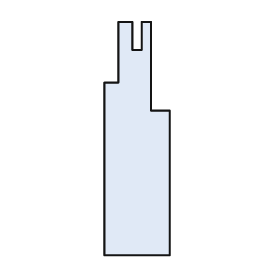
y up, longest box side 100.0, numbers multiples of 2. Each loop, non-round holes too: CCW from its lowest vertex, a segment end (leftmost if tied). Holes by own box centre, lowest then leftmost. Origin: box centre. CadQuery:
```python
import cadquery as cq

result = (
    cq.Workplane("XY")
    .moveTo(-14.0, -50.0)
    .lineTo(14.0, -50.0)
    .lineTo(14.0, 12.0)
    .lineTo(6.0, 12.0)
    .lineTo(6.0, 50.0)
    .lineTo(2.0, 50.0)
    .lineTo(2.0, 38.0)
    .lineTo(-2.0, 38.0)
    .lineTo(-2.0, 50.0)
    .lineTo(-8.0, 50.0)
    .lineTo(-8.0, 24.0)
    .lineTo(-14.0, 24.0)
    .close()
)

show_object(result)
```